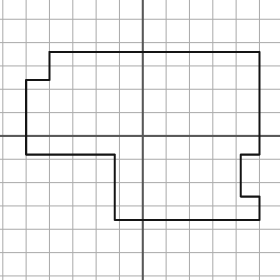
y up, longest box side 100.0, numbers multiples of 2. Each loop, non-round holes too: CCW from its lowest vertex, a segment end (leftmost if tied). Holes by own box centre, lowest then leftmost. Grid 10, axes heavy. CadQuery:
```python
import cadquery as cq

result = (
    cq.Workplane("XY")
    .moveTo(-12.0, -36.0)
    .lineTo(50.0, -36.0)
    .lineTo(50.0, -26.0)
    .lineTo(42.0, -26.0)
    .lineTo(42.0, -8.0)
    .lineTo(50.0, -8.0)
    .lineTo(50.0, 36.0)
    .lineTo(-40.0, 36.0)
    .lineTo(-40.0, 24.0)
    .lineTo(-50.0, 24.0)
    .lineTo(-50.0, -8.0)
    .lineTo(-12.0, -8.0)
    .close()
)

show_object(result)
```